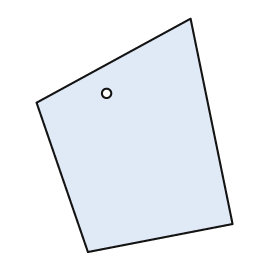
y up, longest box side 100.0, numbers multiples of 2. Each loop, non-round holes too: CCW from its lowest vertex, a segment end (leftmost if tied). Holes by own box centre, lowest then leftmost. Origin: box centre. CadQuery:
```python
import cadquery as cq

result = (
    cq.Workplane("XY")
    .moveTo(-20.0, -50.0)
    .lineTo(42.0, -38.0)
    .lineTo(24.0, 50.0)
    .lineTo(-42.0, 14.0)
    .close()
    .moveTo(-12.0, 18.0)
    .circle(2.0)
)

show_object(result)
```